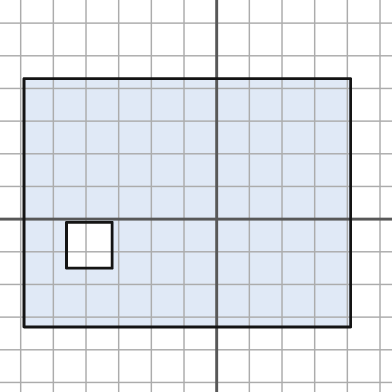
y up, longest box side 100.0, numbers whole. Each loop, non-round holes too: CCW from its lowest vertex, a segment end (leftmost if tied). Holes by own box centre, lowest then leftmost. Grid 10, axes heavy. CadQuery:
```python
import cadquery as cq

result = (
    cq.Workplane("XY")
    .moveTo(-59.0, -33.0)
    .lineTo(41.0, -33.0)
    .lineTo(41.0, 43.0)
    .lineTo(-59.0, 43.0)
    .close()
    .moveTo(-46.0, -15.0)
    .lineTo(-32.0, -15.0)
    .lineTo(-32.0, -1.0)
    .lineTo(-46.0, -1.0)
    .close()
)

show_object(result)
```